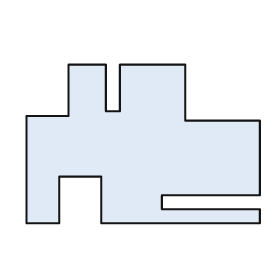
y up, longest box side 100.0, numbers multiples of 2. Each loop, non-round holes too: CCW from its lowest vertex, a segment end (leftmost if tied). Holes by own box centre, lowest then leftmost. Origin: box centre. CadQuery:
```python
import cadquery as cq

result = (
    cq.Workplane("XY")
    .moveTo(-50.0, -34.0)
    .lineTo(-36.0, -34.0)
    .lineTo(-36.0, -14.0)
    .lineTo(-18.0, -14.0)
    .lineTo(-18.0, -34.0)
    .lineTo(50.0, -34.0)
    .lineTo(50.0, -28.0)
    .lineTo(8.0, -28.0)
    .lineTo(8.0, -22.0)
    .lineTo(50.0, -22.0)
    .lineTo(50.0, 10.0)
    .lineTo(18.0, 10.0)
    .lineTo(18.0, 34.0)
    .lineTo(-10.0, 34.0)
    .lineTo(-10.0, 14.0)
    .lineTo(-16.0, 14.0)
    .lineTo(-16.0, 34.0)
    .lineTo(-32.0, 34.0)
    .lineTo(-32.0, 12.0)
    .lineTo(-50.0, 12.0)
    .close()
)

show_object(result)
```